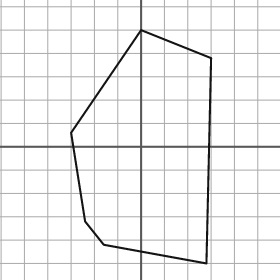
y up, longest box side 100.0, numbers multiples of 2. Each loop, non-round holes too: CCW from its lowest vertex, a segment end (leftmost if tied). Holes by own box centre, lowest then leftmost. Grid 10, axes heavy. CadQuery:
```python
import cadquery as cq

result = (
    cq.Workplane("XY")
    .moveTo(28.0, -50.0)
    .lineTo(30.0, 38.0)
    .lineTo(0.0, 50.0)
    .lineTo(-30.0, 6.0)
    .lineTo(-24.0, -32.0)
    .lineTo(-16.0, -42.0)
    .close()
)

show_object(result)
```